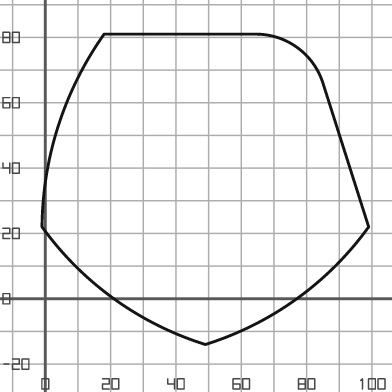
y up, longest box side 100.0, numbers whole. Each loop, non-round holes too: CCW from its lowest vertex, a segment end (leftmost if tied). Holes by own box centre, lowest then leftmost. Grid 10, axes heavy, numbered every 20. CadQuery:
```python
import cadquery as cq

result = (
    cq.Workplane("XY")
    .moveTo(49.0, -14.0)
    .threePointArc((77.0, 0.0), (99.0, 22.0))
    .lineTo(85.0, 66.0)
    .threePointArc((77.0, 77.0), (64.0, 81.0))
    .lineTo(18.0, 81.0)
    .threePointArc((4.0, 53.0), (-1.0, 22.0))
    .threePointArc((21.0, 0.0), (49.0, -14.0))
    .close()
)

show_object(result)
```